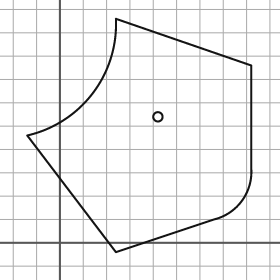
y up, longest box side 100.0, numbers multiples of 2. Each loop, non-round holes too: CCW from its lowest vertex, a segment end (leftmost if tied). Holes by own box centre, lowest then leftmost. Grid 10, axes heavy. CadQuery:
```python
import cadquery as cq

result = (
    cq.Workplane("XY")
    .moveTo(24.0, -4.0)
    .lineTo(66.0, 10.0)
    .threePointArc((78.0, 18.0), (82.0, 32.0))
    .lineTo(82.0, 76.0)
    .lineTo(24.0, 96.0)
    .threePointArc((14.0, 64.0), (-14.0, 46.0))
    .close()
    .moveTo(42.0, 54.0)
    .circle(2.0)
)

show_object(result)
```